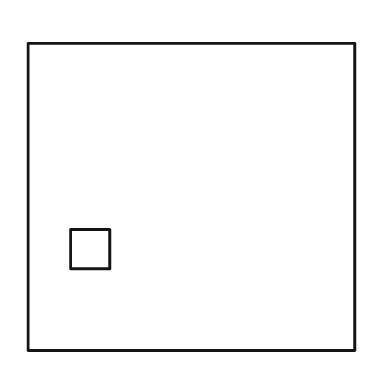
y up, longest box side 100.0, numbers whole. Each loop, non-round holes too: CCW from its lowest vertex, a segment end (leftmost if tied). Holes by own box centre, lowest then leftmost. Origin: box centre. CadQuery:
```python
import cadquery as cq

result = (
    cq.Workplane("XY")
    .moveTo(-50.0, -47.0)
    .lineTo(50.0, -47.0)
    .lineTo(50.0, 47.0)
    .lineTo(-50.0, 47.0)
    .close()
    .moveTo(-37.0, -22.0)
    .lineTo(-25.0, -22.0)
    .lineTo(-25.0, -10.0)
    .lineTo(-37.0, -10.0)
    .close()
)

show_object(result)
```